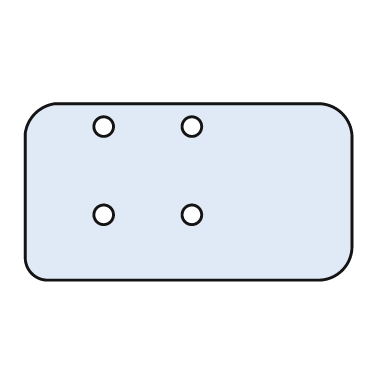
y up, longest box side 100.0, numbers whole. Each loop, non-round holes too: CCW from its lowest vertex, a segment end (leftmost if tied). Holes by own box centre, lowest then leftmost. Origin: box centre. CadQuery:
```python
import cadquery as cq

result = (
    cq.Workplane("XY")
    .moveTo(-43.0, -27.0)
    .lineTo(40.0, -27.0)
    .threePointArc((47.0, -24.0), (50.0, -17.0))
    .lineTo(50.0, 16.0)
    .threePointArc((47.0, 24.0), (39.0, 27.0))
    .lineTo(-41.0, 27.0)
    .threePointArc((-47.0, 24.0), (-50.0, 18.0))
    .lineTo(-50.0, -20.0)
    .threePointArc((-48.0, -25.0), (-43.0, -27.0))
    .close()
    .moveTo(-26.0, -7.0)
    .circle(3.0)
    .moveTo(1.0, -7.0)
    .circle(3.0)
    .moveTo(-26.0, 20.0)
    .circle(3.0)
    .moveTo(1.0, 20.0)
    .circle(3.0)
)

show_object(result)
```